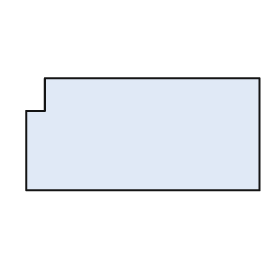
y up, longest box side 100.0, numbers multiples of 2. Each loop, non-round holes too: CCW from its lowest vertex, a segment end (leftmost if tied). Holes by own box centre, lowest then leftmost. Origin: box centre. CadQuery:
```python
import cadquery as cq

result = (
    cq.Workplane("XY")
    .moveTo(-50.0, -24.0)
    .lineTo(50.0, -24.0)
    .lineTo(50.0, 24.0)
    .lineTo(-42.0, 24.0)
    .lineTo(-42.0, 10.0)
    .lineTo(-50.0, 10.0)
    .close()
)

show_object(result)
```